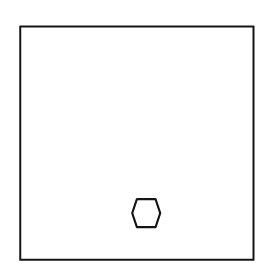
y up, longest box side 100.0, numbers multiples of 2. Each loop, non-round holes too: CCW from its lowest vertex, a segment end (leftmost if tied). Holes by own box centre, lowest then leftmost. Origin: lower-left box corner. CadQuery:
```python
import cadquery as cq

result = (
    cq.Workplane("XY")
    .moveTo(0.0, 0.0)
    .lineTo(100.0, 0.0)
    .lineTo(100.0, 100.0)
    .lineTo(0.0, 100.0)
    .close()
    .moveTo(50.0, 14.0)
    .lineTo(58.0, 14.0)
    .lineTo(60.0, 20.0)
    .lineTo(58.0, 26.0)
    .lineTo(50.0, 26.0)
    .lineTo(48.0, 20.0)
    .close()
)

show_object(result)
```